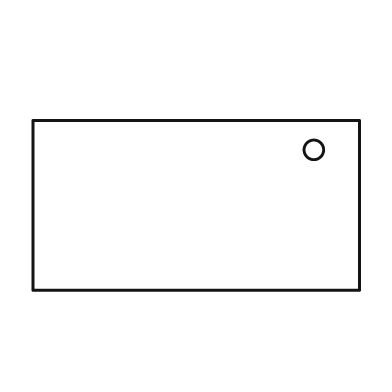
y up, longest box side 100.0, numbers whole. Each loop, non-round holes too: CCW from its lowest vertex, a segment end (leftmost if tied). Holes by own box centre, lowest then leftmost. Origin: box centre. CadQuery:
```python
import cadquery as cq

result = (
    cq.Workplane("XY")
    .moveTo(-50.0, -26.0)
    .lineTo(50.0, -26.0)
    .lineTo(50.0, 26.0)
    .lineTo(-50.0, 26.0)
    .close()
    .moveTo(36.0, 17.0)
    .circle(3.0)
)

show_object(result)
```